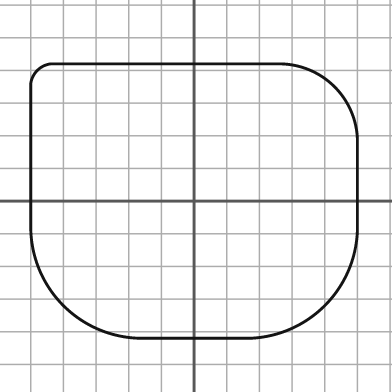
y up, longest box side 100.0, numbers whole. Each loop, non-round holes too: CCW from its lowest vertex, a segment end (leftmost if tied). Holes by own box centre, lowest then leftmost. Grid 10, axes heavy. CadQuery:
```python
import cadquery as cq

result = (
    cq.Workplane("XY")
    .moveTo(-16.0, -42.0)
    .lineTo(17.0, -42.0)
    .threePointArc((40.0, -32.0), (50.0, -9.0))
    .lineTo(50.0, 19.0)
    .threePointArc((43.0, 35.0), (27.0, 42.0))
    .lineTo(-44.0, 42.0)
    .threePointArc((-48.0, 40.0), (-50.0, 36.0))
    .lineTo(-50.0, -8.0)
    .threePointArc((-40.0, -32.0), (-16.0, -42.0))
    .close()
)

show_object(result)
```